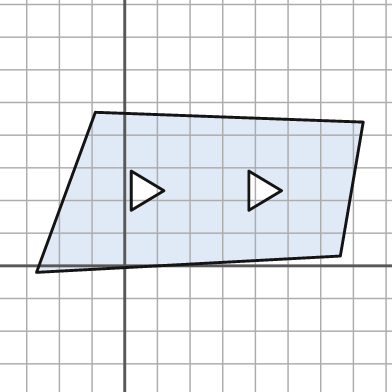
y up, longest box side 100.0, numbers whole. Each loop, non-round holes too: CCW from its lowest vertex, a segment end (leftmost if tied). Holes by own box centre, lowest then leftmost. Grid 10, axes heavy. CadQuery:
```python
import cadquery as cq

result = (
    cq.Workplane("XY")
    .moveTo(-27.0, -2.0)
    .lineTo(66.0, 3.0)
    .lineTo(73.0, 44.0)
    .lineTo(-9.0, 47.0)
    .close()
    .moveTo(2.0, 17.0)
    .lineTo(12.0, 23.0)
    .lineTo(2.0, 29.0)
    .close()
    .moveTo(38.0, 17.0)
    .lineTo(48.0, 23.0)
    .lineTo(38.0, 29.0)
    .close()
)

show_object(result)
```